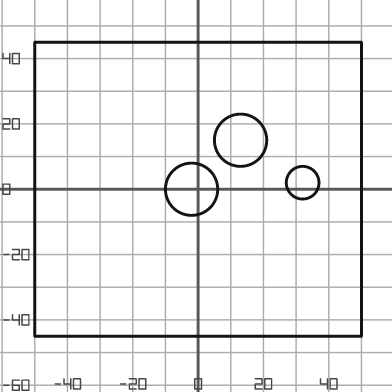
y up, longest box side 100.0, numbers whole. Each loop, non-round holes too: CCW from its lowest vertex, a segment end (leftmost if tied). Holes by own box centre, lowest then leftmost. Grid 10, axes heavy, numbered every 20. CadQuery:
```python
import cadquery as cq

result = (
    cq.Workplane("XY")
    .moveTo(-50.0, -45.0)
    .lineTo(50.0, -45.0)
    .lineTo(50.0, 45.0)
    .lineTo(-50.0, 45.0)
    .close()
    .moveTo(-2.0, 0.0)
    .circle(8.0)
    .moveTo(32.0, 2.0)
    .circle(5.0)
    .moveTo(13.0, 15.0)
    .circle(8.0)
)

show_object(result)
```